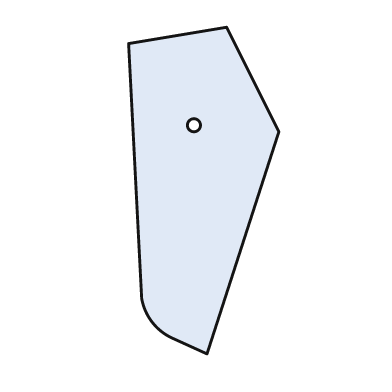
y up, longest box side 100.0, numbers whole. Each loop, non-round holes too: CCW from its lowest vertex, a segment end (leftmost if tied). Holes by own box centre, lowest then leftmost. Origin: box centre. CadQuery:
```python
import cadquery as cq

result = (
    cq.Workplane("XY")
    .moveTo(1.0, -50.0)
    .lineTo(23.0, 18.0)
    .lineTo(7.0, 50.0)
    .lineTo(-23.0, 45.0)
    .lineTo(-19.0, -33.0)
    .threePointArc((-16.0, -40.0), (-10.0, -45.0))
    .close()
    .moveTo(-3.0, 20.0)
    .circle(2.0)
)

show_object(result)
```